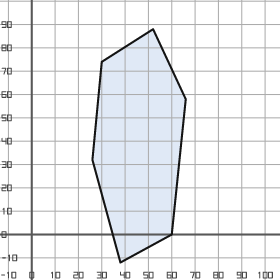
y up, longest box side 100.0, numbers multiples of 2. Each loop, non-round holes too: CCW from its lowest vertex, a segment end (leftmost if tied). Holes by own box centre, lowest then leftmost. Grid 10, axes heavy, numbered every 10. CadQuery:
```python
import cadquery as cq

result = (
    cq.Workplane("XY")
    .moveTo(38.0, -12.0)
    .lineTo(60.0, 0.0)
    .lineTo(66.0, 58.0)
    .lineTo(52.0, 88.0)
    .lineTo(30.0, 74.0)
    .lineTo(26.0, 32.0)
    .close()
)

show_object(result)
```